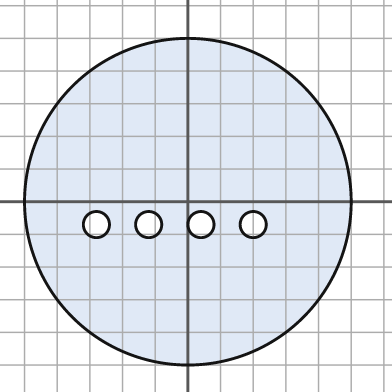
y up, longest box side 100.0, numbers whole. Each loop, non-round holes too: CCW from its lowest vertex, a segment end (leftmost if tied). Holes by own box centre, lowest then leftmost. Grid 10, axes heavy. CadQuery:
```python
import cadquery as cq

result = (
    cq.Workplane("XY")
    .moveTo(0.0, 0.0)
    .circle(50.0)
    .moveTo(-28.0, -7.0)
    .circle(4.0)
    .moveTo(-12.0, -7.0)
    .circle(4.0)
    .moveTo(4.0, -7.0)
    .circle(4.0)
    .moveTo(20.0, -7.0)
    .circle(4.0)
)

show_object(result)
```